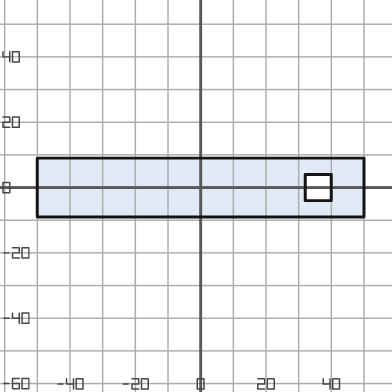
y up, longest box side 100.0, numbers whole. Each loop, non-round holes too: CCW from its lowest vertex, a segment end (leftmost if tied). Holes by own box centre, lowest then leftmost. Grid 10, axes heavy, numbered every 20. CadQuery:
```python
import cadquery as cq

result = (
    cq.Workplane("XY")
    .moveTo(-50.0, -9.0)
    .lineTo(50.0, -9.0)
    .lineTo(50.0, 9.0)
    .lineTo(-50.0, 9.0)
    .close()
    .moveTo(32.0, -4.0)
    .lineTo(40.0, -4.0)
    .lineTo(40.0, 4.0)
    .lineTo(32.0, 4.0)
    .close()
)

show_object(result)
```